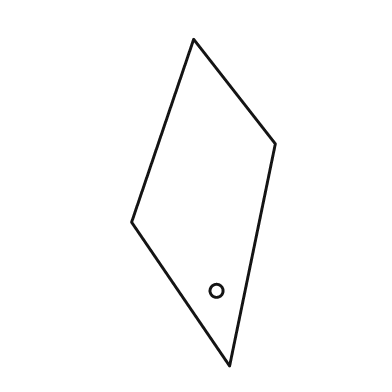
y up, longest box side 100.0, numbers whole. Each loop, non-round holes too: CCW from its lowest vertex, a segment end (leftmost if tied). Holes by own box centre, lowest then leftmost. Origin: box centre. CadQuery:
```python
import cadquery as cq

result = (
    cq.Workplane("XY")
    .moveTo(8.0, -50.0)
    .lineTo(22.0, 18.0)
    .lineTo(-3.0, 50.0)
    .lineTo(-22.0, -6.0)
    .close()
    .moveTo(4.0, -27.0)
    .circle(2.0)
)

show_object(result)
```